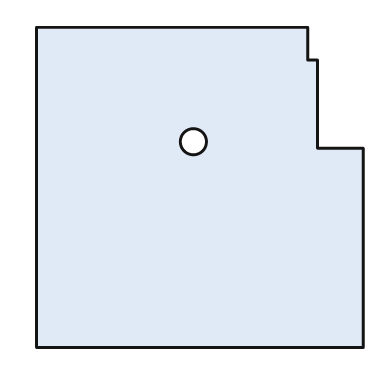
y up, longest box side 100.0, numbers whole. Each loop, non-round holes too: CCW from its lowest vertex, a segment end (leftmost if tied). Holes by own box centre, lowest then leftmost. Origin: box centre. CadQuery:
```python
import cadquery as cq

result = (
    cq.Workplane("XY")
    .moveTo(-50.0, -49.0)
    .lineTo(50.0, -49.0)
    .lineTo(50.0, 12.0)
    .lineTo(36.0, 12.0)
    .lineTo(36.0, 39.0)
    .lineTo(33.0, 39.0)
    .lineTo(33.0, 49.0)
    .lineTo(-50.0, 49.0)
    .close()
    .moveTo(-2.0, 14.0)
    .circle(4.0)
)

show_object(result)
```